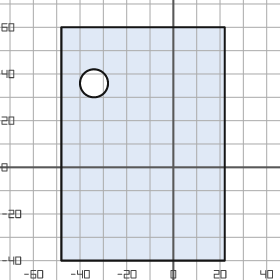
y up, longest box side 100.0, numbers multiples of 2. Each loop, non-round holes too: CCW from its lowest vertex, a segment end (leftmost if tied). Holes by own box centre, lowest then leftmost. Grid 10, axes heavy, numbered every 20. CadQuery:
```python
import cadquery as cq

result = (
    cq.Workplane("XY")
    .moveTo(-48.0, -40.0)
    .lineTo(22.0, -40.0)
    .lineTo(22.0, 60.0)
    .lineTo(-48.0, 60.0)
    .close()
    .moveTo(-34.0, 36.0)
    .circle(6.0)
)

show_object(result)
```